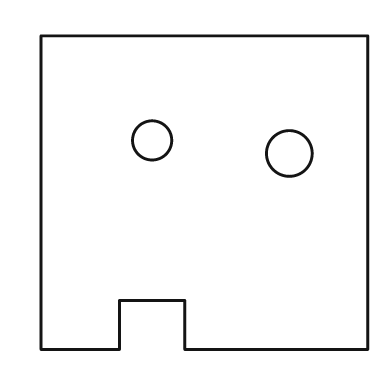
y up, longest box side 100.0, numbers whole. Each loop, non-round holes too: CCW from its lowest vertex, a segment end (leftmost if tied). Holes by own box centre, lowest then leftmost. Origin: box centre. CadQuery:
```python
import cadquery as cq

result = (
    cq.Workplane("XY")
    .moveTo(-50.0, -48.0)
    .lineTo(-26.0, -48.0)
    .lineTo(-26.0, -33.0)
    .lineTo(-6.0, -33.0)
    .lineTo(-6.0, -48.0)
    .lineTo(50.0, -48.0)
    .lineTo(50.0, 48.0)
    .lineTo(-50.0, 48.0)
    .close()
    .moveTo(26.0, 12.0)
    .circle(7.0)
    .moveTo(-16.0, 16.0)
    .circle(6.0)
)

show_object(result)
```